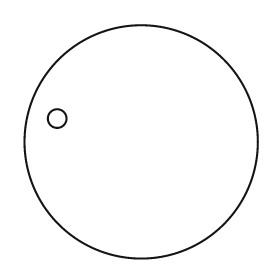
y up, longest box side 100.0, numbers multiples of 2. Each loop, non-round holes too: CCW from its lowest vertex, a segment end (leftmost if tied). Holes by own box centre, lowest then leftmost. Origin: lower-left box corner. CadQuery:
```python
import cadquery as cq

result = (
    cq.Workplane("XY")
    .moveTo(50.0, 50.0)
    .circle(50.0)
    .moveTo(14.0, 60.0)
    .circle(4.0)
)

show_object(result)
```